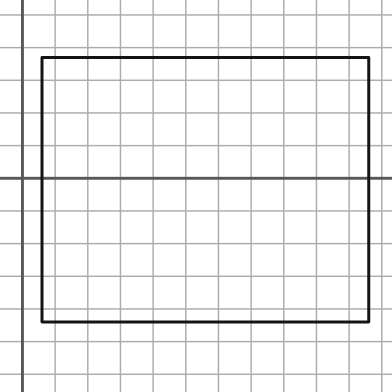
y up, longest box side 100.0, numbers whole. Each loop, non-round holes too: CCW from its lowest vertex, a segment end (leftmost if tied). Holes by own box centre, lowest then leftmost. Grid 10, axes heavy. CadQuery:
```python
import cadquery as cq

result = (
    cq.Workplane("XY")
    .moveTo(6.0, -44.0)
    .lineTo(106.0, -44.0)
    .lineTo(106.0, 37.0)
    .lineTo(6.0, 37.0)
    .close()
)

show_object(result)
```